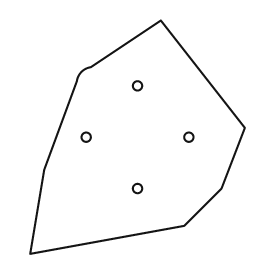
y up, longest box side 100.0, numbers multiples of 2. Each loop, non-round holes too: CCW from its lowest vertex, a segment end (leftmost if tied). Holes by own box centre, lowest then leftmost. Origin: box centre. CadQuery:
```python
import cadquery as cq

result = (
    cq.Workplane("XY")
    .moveTo(-46.0, -50.0)
    .lineTo(20.0, -38.0)
    .lineTo(36.0, -22.0)
    .lineTo(46.0, 4.0)
    .lineTo(10.0, 50.0)
    .lineTo(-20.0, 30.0)
    .threePointArc((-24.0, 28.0), (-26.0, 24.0))
    .lineTo(-40.0, -14.0)
    .close()
    .moveTo(0.0, -22.0)
    .circle(2.0)
    .moveTo(-22.0, 0.0)
    .circle(2.0)
    .moveTo(22.0, 0.0)
    .circle(2.0)
    .moveTo(0.0, 22.0)
    .circle(2.0)
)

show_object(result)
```